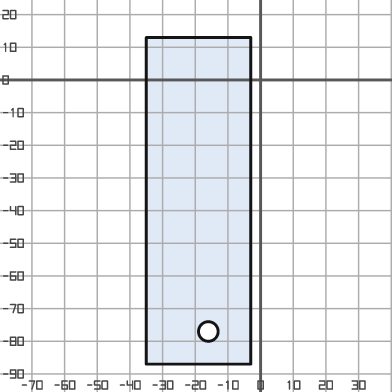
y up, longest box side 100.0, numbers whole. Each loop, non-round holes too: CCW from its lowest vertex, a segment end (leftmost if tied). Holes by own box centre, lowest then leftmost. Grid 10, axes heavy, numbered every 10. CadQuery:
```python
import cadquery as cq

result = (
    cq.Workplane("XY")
    .moveTo(-35.0, -87.0)
    .lineTo(-3.0, -87.0)
    .lineTo(-3.0, 13.0)
    .lineTo(-35.0, 13.0)
    .close()
    .moveTo(-16.0, -77.0)
    .circle(3.0)
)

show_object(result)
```